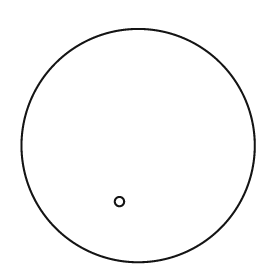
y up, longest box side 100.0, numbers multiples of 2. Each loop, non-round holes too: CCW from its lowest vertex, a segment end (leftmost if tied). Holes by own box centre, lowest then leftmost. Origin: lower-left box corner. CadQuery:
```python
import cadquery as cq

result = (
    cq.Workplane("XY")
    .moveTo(50.0, 50.0)
    .circle(50.0)
    .moveTo(42.0, 26.0)
    .circle(2.0)
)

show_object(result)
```